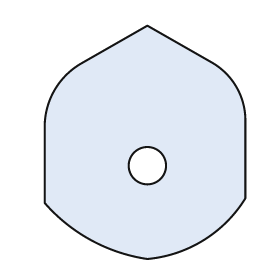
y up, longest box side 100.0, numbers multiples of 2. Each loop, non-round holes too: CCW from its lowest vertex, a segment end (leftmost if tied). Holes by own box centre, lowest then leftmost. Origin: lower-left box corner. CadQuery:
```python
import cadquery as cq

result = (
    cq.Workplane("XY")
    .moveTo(44.0, 0.0)
    .threePointArc((68.0, 8.0), (86.0, 26.0))
    .lineTo(86.0, 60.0)
    .threePointArc((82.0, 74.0), (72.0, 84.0))
    .lineTo(44.0, 100.0)
    .lineTo(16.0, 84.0)
    .threePointArc((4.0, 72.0), (0.0, 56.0))
    .lineTo(0.0, 24.0)
    .threePointArc((20.0, 8.0), (44.0, 0.0))
    .close()
    .moveTo(44.0, 40.0)
    .circle(8.0)
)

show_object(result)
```